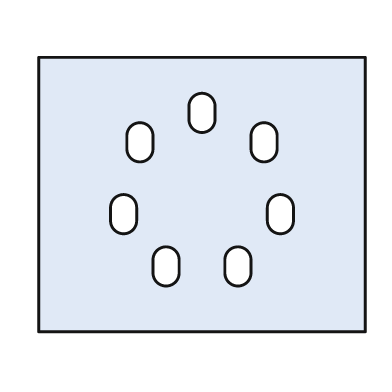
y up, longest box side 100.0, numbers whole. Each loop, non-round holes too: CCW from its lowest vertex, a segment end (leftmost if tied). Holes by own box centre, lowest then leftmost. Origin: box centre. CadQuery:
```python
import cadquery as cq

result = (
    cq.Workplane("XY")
    .moveTo(-50.0, -42.0)
    .lineTo(50.0, -42.0)
    .lineTo(50.0, 42.0)
    .lineTo(-50.0, 42.0)
    .close()
    .moveTo(-15.0, -24.0)
    .threePointArc((-11.0, -28.0), (-7.0, -24.0))
    .lineTo(-7.0, -20.0)
    .threePointArc((-11.0, -16.0), (-15.0, -20.0))
    .close()
    .moveTo(7.0, -24.0)
    .threePointArc((11.0, -28.0), (15.0, -24.0))
    .lineTo(15.0, -20.0)
    .threePointArc((11.0, -16.0), (7.0, -20.0))
    .close()
    .moveTo(-28.0, -8.0)
    .threePointArc((-24.0, -12.0), (-20.0, -8.0))
    .lineTo(-20.0, -4.0)
    .threePointArc((-24.0, 0.0), (-28.0, -4.0))
    .close()
    .moveTo(20.0, -8.0)
    .threePointArc((24.0, -12.0), (28.0, -8.0))
    .lineTo(28.0, -4.0)
    .threePointArc((24.0, 0.0), (20.0, -4.0))
    .close()
    .moveTo(-23.0, 14.0)
    .threePointArc((-19.0, 10.0), (-15.0, 14.0))
    .lineTo(-15.0, 18.0)
    .threePointArc((-19.0, 22.0), (-23.0, 18.0))
    .close()
    .moveTo(15.0, 14.0)
    .threePointArc((19.0, 10.0), (23.0, 14.0))
    .lineTo(23.0, 18.0)
    .threePointArc((19.0, 22.0), (15.0, 18.0))
    .close()
    .moveTo(-4.0, 23.0)
    .threePointArc((0.0, 19.0), (4.0, 23.0))
    .lineTo(4.0, 27.0)
    .threePointArc((0.0, 31.0), (-4.0, 27.0))
    .close()
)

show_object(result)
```